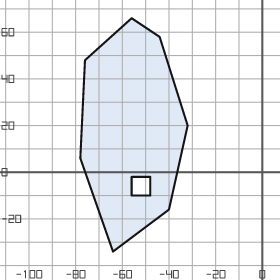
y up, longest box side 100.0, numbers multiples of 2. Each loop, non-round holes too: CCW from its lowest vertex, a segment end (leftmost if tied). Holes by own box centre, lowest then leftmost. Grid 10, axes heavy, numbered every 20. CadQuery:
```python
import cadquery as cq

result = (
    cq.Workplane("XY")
    .moveTo(-64.0, -34.0)
    .lineTo(-40.0, -16.0)
    .lineTo(-32.0, 20.0)
    .lineTo(-44.0, 58.0)
    .lineTo(-56.0, 66.0)
    .lineTo(-76.0, 48.0)
    .lineTo(-78.0, 6.0)
    .close()
    .moveTo(-56.0, -10.0)
    .lineTo(-48.0, -10.0)
    .lineTo(-48.0, -2.0)
    .lineTo(-56.0, -2.0)
    .close()
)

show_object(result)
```